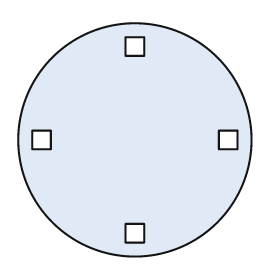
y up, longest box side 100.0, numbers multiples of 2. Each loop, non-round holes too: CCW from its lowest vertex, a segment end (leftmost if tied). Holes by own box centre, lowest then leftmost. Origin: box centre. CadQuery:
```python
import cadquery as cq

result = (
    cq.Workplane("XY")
    .moveTo(0.0, 0.0)
    .circle(50.0)
    .moveTo(-4.0, -44.0)
    .lineTo(4.0, -44.0)
    .lineTo(4.0, -36.0)
    .lineTo(-4.0, -36.0)
    .close()
    .moveTo(-44.0, -4.0)
    .lineTo(-36.0, -4.0)
    .lineTo(-36.0, 4.0)
    .lineTo(-44.0, 4.0)
    .close()
    .moveTo(36.0, -4.0)
    .lineTo(44.0, -4.0)
    .lineTo(44.0, 4.0)
    .lineTo(36.0, 4.0)
    .close()
    .moveTo(-4.0, 36.0)
    .lineTo(4.0, 36.0)
    .lineTo(4.0, 44.0)
    .lineTo(-4.0, 44.0)
    .close()
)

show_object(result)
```